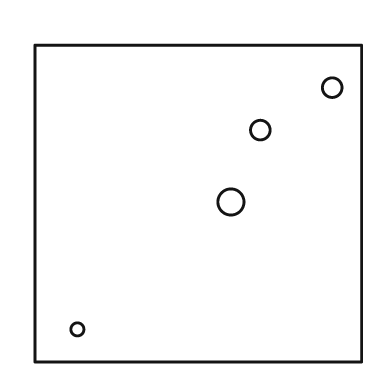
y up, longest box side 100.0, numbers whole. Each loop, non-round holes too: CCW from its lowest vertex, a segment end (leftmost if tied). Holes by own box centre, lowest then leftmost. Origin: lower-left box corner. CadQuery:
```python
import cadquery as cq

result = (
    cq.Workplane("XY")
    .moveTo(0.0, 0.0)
    .lineTo(100.0, 0.0)
    .lineTo(100.0, 97.0)
    .lineTo(0.0, 97.0)
    .close()
    .moveTo(13.0, 10.0)
    .circle(2.0)
    .moveTo(60.0, 49.0)
    .circle(4.0)
    .moveTo(69.0, 71.0)
    .circle(3.0)
    .moveTo(91.0, 84.0)
    .circle(3.0)
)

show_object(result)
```